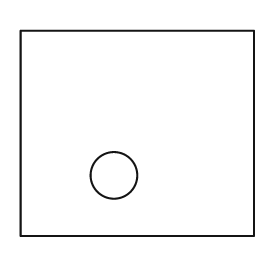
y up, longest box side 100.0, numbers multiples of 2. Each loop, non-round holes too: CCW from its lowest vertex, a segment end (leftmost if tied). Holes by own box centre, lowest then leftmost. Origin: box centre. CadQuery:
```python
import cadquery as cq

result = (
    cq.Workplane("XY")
    .moveTo(-50.0, -44.0)
    .lineTo(50.0, -44.0)
    .lineTo(50.0, 44.0)
    .lineTo(-50.0, 44.0)
    .close()
    .moveTo(-10.0, -18.0)
    .circle(10.0)
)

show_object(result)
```